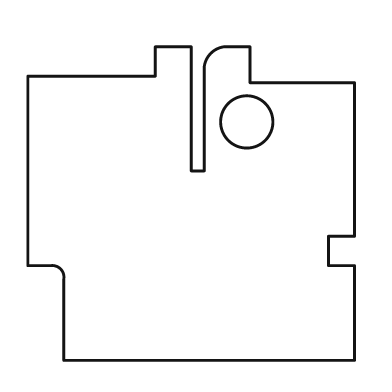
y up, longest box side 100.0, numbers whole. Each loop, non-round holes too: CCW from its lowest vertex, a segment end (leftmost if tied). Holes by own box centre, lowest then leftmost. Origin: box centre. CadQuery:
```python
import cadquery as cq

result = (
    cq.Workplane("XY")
    .moveTo(-39.0, -48.0)
    .lineTo(50.0, -48.0)
    .lineTo(50.0, -19.0)
    .lineTo(42.0, -19.0)
    .lineTo(42.0, -10.0)
    .lineTo(50.0, -10.0)
    .lineTo(50.0, 37.0)
    .lineTo(18.0, 37.0)
    .lineTo(18.0, 48.0)
    .lineTo(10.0, 48.0)
    .threePointArc((6.0, 46.0), (4.0, 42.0))
    .lineTo(4.0, 10.0)
    .lineTo(0.0, 10.0)
    .lineTo(0.0, 48.0)
    .lineTo(-11.0, 48.0)
    .lineTo(-11.0, 39.0)
    .lineTo(-50.0, 39.0)
    .lineTo(-50.0, -19.0)
    .lineTo(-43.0, -19.0)
    .threePointArc((-40.0, -20.0), (-39.0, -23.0))
    .close()
    .moveTo(17.0, 25.0)
    .circle(8.0)
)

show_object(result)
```